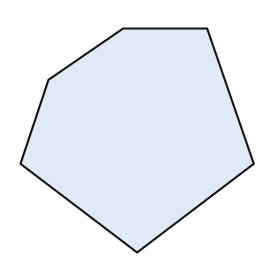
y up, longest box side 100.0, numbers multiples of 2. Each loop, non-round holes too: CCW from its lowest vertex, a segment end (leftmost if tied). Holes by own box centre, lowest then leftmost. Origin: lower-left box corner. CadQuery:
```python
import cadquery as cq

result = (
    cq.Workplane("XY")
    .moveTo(50.0, 0.0)
    .lineTo(100.0, 38.0)
    .lineTo(80.0, 96.0)
    .lineTo(44.0, 96.0)
    .lineTo(12.0, 74.0)
    .lineTo(0.0, 38.0)
    .close()
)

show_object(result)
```